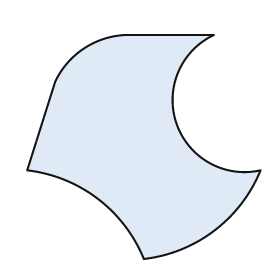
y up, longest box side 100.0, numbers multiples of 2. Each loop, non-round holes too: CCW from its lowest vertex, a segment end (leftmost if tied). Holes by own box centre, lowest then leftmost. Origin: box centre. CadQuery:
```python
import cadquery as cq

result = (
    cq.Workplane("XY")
    .moveTo(0.0, -48.0)
    .threePointArc((30.0, -36.0), (50.0, -10.0))
    .threePointArc((14.0, 10.0), (30.0, 48.0))
    .lineTo(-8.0, 48.0)
    .threePointArc((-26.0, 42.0), (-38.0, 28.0))
    .lineTo(-50.0, -10.0)
    .threePointArc((-20.0, -22.0), (0.0, -48.0))
    .close()
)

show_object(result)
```